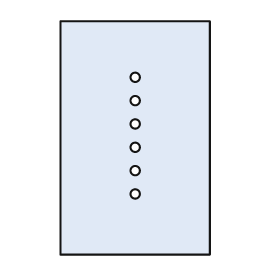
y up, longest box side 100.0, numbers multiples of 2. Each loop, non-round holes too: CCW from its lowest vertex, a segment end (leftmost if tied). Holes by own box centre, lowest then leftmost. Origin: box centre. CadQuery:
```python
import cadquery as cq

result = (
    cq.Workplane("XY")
    .moveTo(-32.0, -50.0)
    .lineTo(32.0, -50.0)
    .lineTo(32.0, 50.0)
    .lineTo(-32.0, 50.0)
    .close()
    .moveTo(0.0, -24.0)
    .circle(2.0)
    .moveTo(0.0, -14.0)
    .circle(2.0)
    .moveTo(0.0, -4.0)
    .circle(2.0)
    .moveTo(0.0, 6.0)
    .circle(2.0)
    .moveTo(0.0, 16.0)
    .circle(2.0)
    .moveTo(0.0, 26.0)
    .circle(2.0)
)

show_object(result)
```